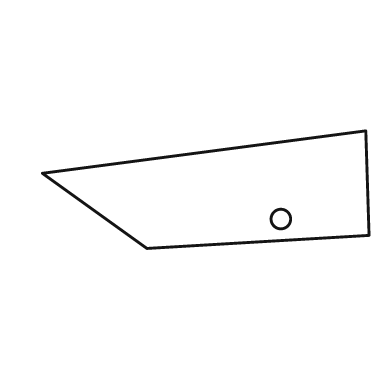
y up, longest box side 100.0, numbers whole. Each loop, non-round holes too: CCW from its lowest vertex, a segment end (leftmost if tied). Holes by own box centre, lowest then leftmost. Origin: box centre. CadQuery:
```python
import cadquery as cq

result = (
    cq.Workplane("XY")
    .moveTo(-18.0, -18.0)
    .lineTo(50.0, -14.0)
    .lineTo(49.0, 18.0)
    .lineTo(-50.0, 5.0)
    .close()
    .moveTo(23.0, -9.0)
    .circle(3.0)
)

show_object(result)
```